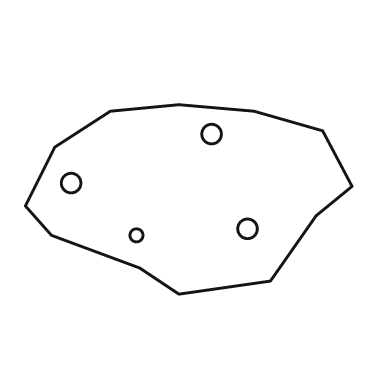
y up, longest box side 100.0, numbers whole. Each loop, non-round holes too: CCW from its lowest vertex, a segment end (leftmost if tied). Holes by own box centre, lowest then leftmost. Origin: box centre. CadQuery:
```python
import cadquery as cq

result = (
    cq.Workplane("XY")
    .moveTo(-3.0, -29.0)
    .lineTo(25.0, -25.0)
    .lineTo(39.0, -5.0)
    .lineTo(50.0, 4.0)
    .lineTo(41.0, 21.0)
    .lineTo(20.0, 27.0)
    .lineTo(-3.0, 29.0)
    .lineTo(-24.0, 27.0)
    .lineTo(-41.0, 16.0)
    .lineTo(-50.0, -2.0)
    .lineTo(-42.0, -11.0)
    .lineTo(-15.0, -21.0)
    .close()
    .moveTo(-16.0, -11.0)
    .circle(2.0)
    .moveTo(18.0, -9.0)
    .circle(3.0)
    .moveTo(-36.0, 5.0)
    .circle(3.0)
    .moveTo(7.0, 20.0)
    .circle(3.0)
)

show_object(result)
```